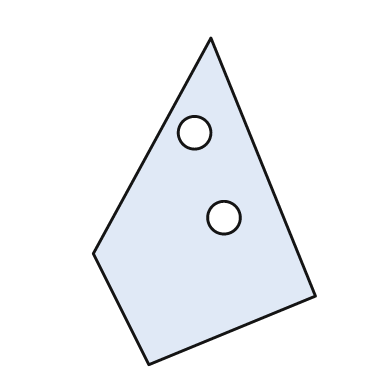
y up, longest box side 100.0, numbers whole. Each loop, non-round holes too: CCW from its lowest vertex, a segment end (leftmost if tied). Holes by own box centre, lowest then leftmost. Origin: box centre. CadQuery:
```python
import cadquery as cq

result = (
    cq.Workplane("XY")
    .moveTo(-17.0, -50.0)
    .lineTo(34.0, -29.0)
    .lineTo(2.0, 50.0)
    .lineTo(-34.0, -16.0)
    .close()
    .moveTo(6.0, -5.0)
    .circle(5.0)
    .moveTo(-3.0, 21.0)
    .circle(5.0)
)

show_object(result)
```